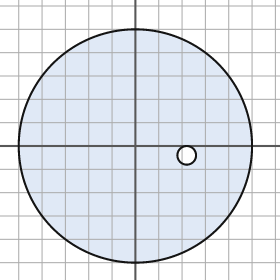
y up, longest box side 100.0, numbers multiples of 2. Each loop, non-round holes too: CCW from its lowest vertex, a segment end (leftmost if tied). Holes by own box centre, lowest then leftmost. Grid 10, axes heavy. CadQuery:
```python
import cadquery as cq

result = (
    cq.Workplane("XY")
    .moveTo(0.0, 0.0)
    .circle(50.0)
    .moveTo(22.0, -4.0)
    .circle(4.0)
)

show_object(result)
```